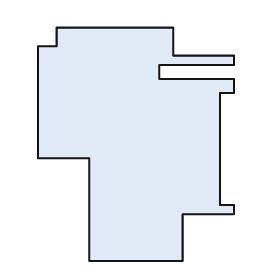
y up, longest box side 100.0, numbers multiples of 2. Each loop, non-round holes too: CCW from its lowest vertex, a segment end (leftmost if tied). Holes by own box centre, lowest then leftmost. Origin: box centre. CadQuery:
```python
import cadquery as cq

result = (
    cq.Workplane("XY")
    .moveTo(-20.0, -50.0)
    .lineTo(20.0, -50.0)
    .lineTo(20.0, -30.0)
    .lineTo(42.0, -30.0)
    .lineTo(42.0, -26.0)
    .lineTo(36.0, -26.0)
    .lineTo(36.0, 22.0)
    .lineTo(42.0, 22.0)
    .lineTo(42.0, 28.0)
    .lineTo(10.0, 28.0)
    .lineTo(10.0, 34.0)
    .lineTo(42.0, 34.0)
    .lineTo(42.0, 38.0)
    .lineTo(16.0, 38.0)
    .lineTo(16.0, 50.0)
    .lineTo(-34.0, 50.0)
    .lineTo(-34.0, 42.0)
    .lineTo(-42.0, 42.0)
    .lineTo(-42.0, -6.0)
    .lineTo(-20.0, -6.0)
    .close()
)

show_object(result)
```